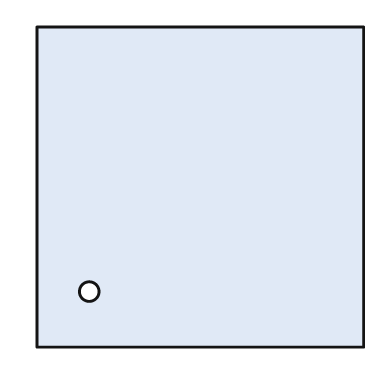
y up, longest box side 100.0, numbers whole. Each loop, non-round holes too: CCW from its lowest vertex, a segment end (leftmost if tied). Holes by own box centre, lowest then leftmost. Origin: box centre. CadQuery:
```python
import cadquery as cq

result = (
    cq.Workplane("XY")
    .moveTo(-50.0, -49.0)
    .lineTo(50.0, -49.0)
    .lineTo(50.0, 49.0)
    .lineTo(-50.0, 49.0)
    .close()
    .moveTo(-34.0, -32.0)
    .circle(3.0)
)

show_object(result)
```